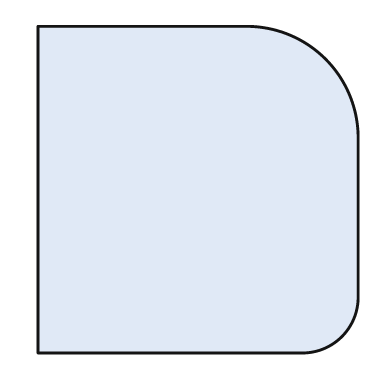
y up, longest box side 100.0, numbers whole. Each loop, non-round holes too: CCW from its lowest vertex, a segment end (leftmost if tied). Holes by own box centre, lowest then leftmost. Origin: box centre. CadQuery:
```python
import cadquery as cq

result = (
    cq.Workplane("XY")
    .moveTo(-49.0, -50.0)
    .lineTo(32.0, -50.0)
    .threePointArc((44.0, -45.0), (49.0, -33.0))
    .lineTo(49.0, 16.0)
    .threePointArc((39.0, 40.0), (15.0, 50.0))
    .lineTo(-49.0, 50.0)
    .close()
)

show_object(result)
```